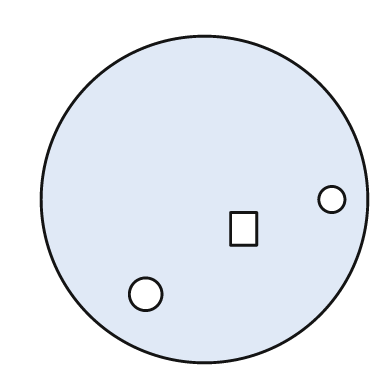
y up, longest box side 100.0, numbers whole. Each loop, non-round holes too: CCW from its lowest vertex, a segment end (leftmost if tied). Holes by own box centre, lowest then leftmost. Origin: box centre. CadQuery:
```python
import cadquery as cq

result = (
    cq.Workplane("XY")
    .moveTo(0.0, 0.0)
    .circle(50.0)
    .moveTo(-18.0, -29.0)
    .circle(5.0)
    .moveTo(8.0, -14.0)
    .lineTo(16.0, -14.0)
    .lineTo(16.0, -4.0)
    .lineTo(8.0, -4.0)
    .close()
    .moveTo(39.0, 0.0)
    .circle(4.0)
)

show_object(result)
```